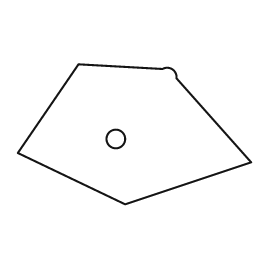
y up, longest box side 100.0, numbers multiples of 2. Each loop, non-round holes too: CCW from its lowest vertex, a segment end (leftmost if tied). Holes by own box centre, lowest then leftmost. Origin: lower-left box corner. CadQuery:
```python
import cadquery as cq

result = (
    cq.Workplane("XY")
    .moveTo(46.0, 0.0)
    .lineTo(100.0, 18.0)
    .lineTo(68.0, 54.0)
    .threePointArc((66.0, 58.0), (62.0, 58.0))
    .lineTo(26.0, 60.0)
    .lineTo(0.0, 22.0)
    .close()
    .moveTo(42.0, 28.0)
    .circle(4.0)
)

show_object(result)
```